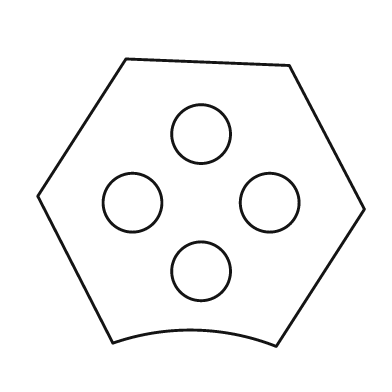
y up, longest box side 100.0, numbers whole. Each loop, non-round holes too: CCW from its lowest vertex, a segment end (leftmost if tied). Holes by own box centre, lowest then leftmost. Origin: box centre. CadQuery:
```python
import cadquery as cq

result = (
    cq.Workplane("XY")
    .moveTo(23.0, -44.0)
    .lineTo(50.0, -2.0)
    .lineTo(27.0, 42.0)
    .lineTo(-23.0, 44.0)
    .lineTo(-50.0, 2.0)
    .lineTo(-27.0, -43.0)
    .threePointArc((-2.0, -39.0), (23.0, -44.0))
    .close()
    .moveTo(0.0, -21.0)
    .circle(9.0)
    .moveTo(-21.0, 0.0)
    .circle(9.0)
    .moveTo(21.0, 0.0)
    .circle(9.0)
    .moveTo(0.0, 21.0)
    .circle(9.0)
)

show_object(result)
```